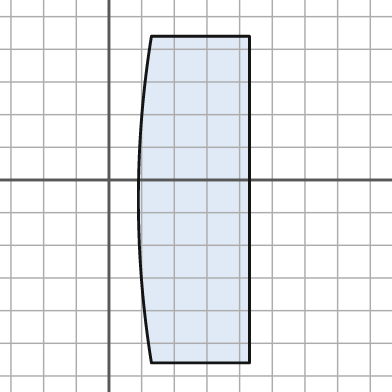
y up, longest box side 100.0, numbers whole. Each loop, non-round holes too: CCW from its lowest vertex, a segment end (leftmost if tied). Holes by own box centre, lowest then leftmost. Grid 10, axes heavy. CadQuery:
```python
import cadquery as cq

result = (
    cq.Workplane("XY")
    .moveTo(13.0, -56.0)
    .lineTo(43.0, -56.0)
    .lineTo(43.0, 44.0)
    .lineTo(13.0, 44.0)
    .threePointArc((9.0, -6.0), (13.0, -56.0))
    .close()
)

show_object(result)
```